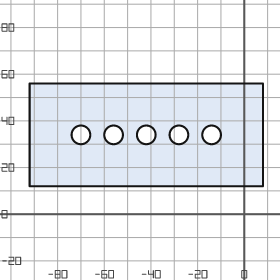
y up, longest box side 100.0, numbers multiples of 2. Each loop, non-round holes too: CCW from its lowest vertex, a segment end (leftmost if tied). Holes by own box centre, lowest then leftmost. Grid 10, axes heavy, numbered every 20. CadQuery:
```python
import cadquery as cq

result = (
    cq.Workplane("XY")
    .moveTo(-92.0, 12.0)
    .lineTo(8.0, 12.0)
    .lineTo(8.0, 56.0)
    .lineTo(-92.0, 56.0)
    .close()
    .moveTo(-70.0, 34.0)
    .circle(4.0)
    .moveTo(-56.0, 34.0)
    .circle(4.0)
    .moveTo(-42.0, 34.0)
    .circle(4.0)
    .moveTo(-28.0, 34.0)
    .circle(4.0)
    .moveTo(-14.0, 34.0)
    .circle(4.0)
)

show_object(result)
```